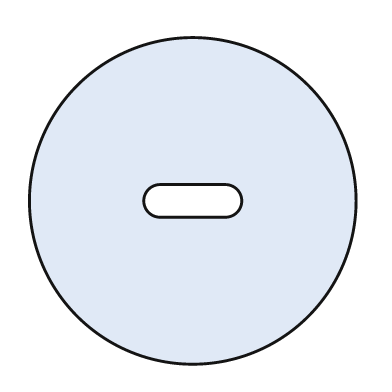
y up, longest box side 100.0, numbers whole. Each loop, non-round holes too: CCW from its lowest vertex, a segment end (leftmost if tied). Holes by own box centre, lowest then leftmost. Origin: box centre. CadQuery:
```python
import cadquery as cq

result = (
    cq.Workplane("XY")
    .moveTo(0.0, 0.0)
    .circle(50.0)
    .moveTo(-10.0, -5.0)
    .lineTo(10.0, -5.0)
    .threePointArc((15.0, 0.0), (10.0, 5.0))
    .lineTo(-10.0, 5.0)
    .threePointArc((-15.0, 0.0), (-10.0, -5.0))
    .close()
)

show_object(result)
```